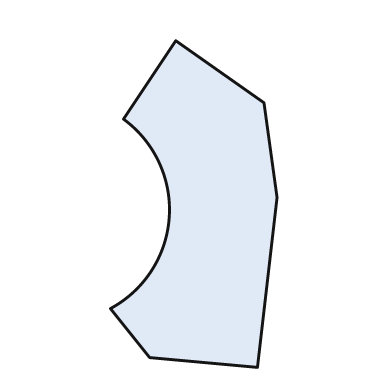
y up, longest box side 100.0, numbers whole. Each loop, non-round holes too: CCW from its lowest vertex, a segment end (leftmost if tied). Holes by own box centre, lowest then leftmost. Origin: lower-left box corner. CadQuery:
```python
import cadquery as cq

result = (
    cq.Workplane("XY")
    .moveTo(45.0, 0.0)
    .lineTo(51.0, 52.0)
    .lineTo(47.0, 81.0)
    .lineTo(20.0, 100.0)
    .lineTo(4.0, 76.0)
    .threePointArc((18.0, 46.0), (0.0, 18.0))
    .lineTo(12.0, 3.0)
    .close()
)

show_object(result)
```